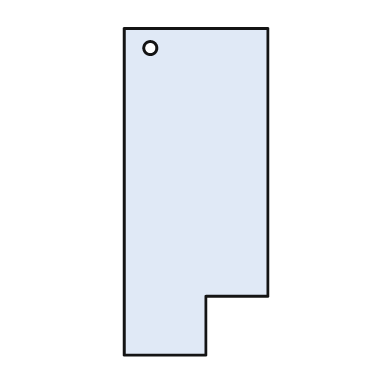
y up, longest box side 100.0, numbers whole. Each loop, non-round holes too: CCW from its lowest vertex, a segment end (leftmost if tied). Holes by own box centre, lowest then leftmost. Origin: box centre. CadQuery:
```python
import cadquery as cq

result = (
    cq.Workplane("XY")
    .moveTo(-22.0, -50.0)
    .lineTo(3.0, -50.0)
    .lineTo(3.0, -32.0)
    .lineTo(22.0, -32.0)
    .lineTo(22.0, 50.0)
    .lineTo(-22.0, 50.0)
    .close()
    .moveTo(-14.0, 44.0)
    .circle(2.0)
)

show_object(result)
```